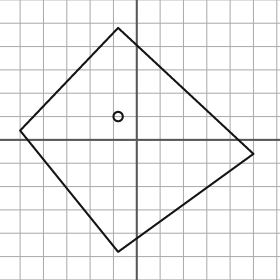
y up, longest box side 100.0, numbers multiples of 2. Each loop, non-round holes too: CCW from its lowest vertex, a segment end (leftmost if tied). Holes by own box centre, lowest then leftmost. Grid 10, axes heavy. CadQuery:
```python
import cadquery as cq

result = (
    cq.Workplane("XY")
    .moveTo(-8.0, -48.0)
    .lineTo(50.0, -6.0)
    .lineTo(-8.0, 48.0)
    .lineTo(-50.0, 4.0)
    .close()
    .moveTo(-8.0, 10.0)
    .circle(2.0)
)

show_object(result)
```